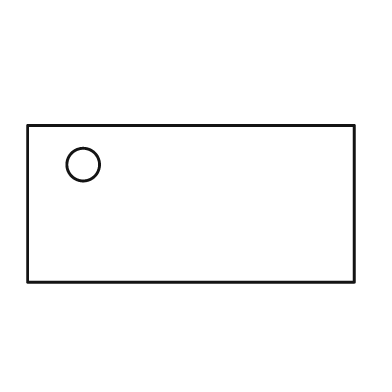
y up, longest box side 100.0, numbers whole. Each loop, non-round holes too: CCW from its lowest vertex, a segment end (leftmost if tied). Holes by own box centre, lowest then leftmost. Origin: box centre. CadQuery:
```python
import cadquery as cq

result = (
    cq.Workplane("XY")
    .moveTo(-50.0, -24.0)
    .lineTo(50.0, -24.0)
    .lineTo(50.0, 24.0)
    .lineTo(-50.0, 24.0)
    .close()
    .moveTo(-33.0, 12.0)
    .circle(5.0)
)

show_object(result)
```